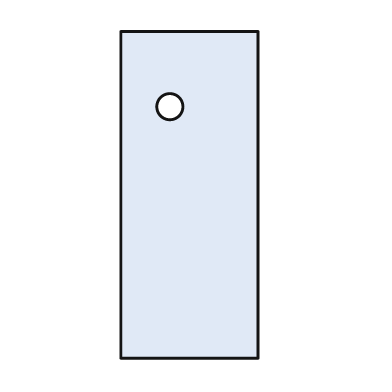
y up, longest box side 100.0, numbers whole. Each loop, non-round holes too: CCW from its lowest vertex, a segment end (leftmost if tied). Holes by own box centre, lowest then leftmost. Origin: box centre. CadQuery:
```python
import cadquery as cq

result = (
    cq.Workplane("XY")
    .moveTo(-21.0, -50.0)
    .lineTo(21.0, -50.0)
    .lineTo(21.0, 50.0)
    .lineTo(-21.0, 50.0)
    .close()
    .moveTo(-6.0, 27.0)
    .circle(4.0)
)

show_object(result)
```